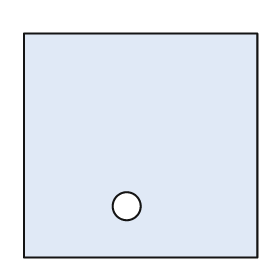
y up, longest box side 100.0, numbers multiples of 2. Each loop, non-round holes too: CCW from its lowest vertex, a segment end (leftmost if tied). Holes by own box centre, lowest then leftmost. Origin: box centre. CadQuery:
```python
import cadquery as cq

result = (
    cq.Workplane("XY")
    .moveTo(-50.0, -48.0)
    .lineTo(50.0, -48.0)
    .lineTo(50.0, 48.0)
    .lineTo(-50.0, 48.0)
    .close()
    .moveTo(-6.0, -26.0)
    .circle(6.0)
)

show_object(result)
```